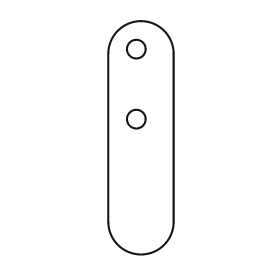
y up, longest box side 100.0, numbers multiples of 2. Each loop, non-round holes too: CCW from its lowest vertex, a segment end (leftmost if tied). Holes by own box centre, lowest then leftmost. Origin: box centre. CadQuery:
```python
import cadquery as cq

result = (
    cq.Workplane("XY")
    .moveTo(-14.0, -36.0)
    .threePointArc((0.0, -50.0), (14.0, -36.0))
    .lineTo(14.0, 36.0)
    .threePointArc((0.0, 50.0), (-14.0, 36.0))
    .close()
    .moveTo(-2.0, 8.0)
    .circle(4.0)
    .moveTo(-2.0, 38.0)
    .circle(4.0)
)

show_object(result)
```